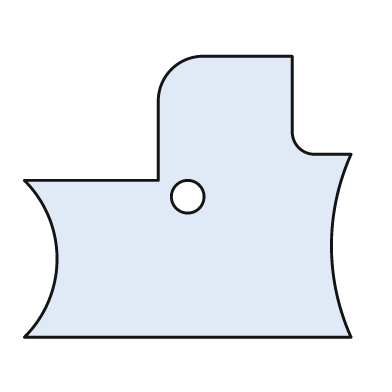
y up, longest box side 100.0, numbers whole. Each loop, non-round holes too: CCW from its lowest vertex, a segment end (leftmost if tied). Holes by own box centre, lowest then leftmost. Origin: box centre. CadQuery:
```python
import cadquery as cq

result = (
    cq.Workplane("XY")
    .moveTo(-50.0, -43.0)
    .lineTo(50.0, -43.0)
    .threePointArc((44.0, -15.0), (50.0, 13.0))
    .lineTo(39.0, 13.0)
    .threePointArc((34.0, 15.0), (32.0, 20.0))
    .lineTo(32.0, 43.0)
    .lineTo(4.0, 43.0)
    .threePointArc((-5.0, 39.0), (-9.0, 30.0))
    .lineTo(-9.0, 5.0)
    .lineTo(-50.0, 5.0)
    .threePointArc((-40.0, -19.0), (-50.0, -43.0))
    .close()
    .moveTo(0.0, 0.0)
    .circle(5.0)
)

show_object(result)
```